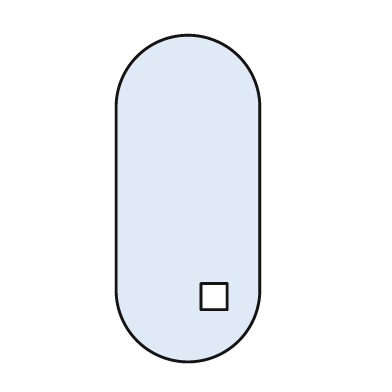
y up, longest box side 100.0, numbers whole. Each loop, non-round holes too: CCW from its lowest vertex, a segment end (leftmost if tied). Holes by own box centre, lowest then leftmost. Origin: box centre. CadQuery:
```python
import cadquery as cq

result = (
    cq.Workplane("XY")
    .moveTo(-22.0, -28.0)
    .threePointArc((0.0, -50.0), (22.0, -28.0))
    .lineTo(22.0, 28.0)
    .threePointArc((0.0, 50.0), (-22.0, 28.0))
    .close()
    .moveTo(4.0, -34.0)
    .lineTo(12.0, -34.0)
    .lineTo(12.0, -26.0)
    .lineTo(4.0, -26.0)
    .close()
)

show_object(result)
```